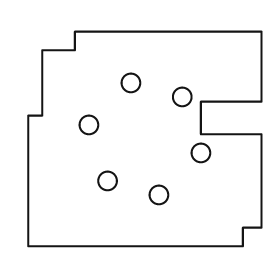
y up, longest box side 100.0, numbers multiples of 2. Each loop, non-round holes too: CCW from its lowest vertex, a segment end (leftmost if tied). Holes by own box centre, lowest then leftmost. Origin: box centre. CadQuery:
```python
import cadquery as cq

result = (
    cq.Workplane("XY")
    .moveTo(-50.0, -46.0)
    .lineTo(42.0, -46.0)
    .lineTo(42.0, -38.0)
    .lineTo(50.0, -38.0)
    .lineTo(50.0, 2.0)
    .lineTo(24.0, 2.0)
    .lineTo(24.0, 16.0)
    .lineTo(50.0, 16.0)
    .lineTo(50.0, 46.0)
    .lineTo(-30.0, 46.0)
    .lineTo(-30.0, 38.0)
    .lineTo(-44.0, 38.0)
    .lineTo(-44.0, 10.0)
    .lineTo(-50.0, 10.0)
    .close()
    .moveTo(6.0, -24.0)
    .circle(4.0)
    .moveTo(-16.0, -18.0)
    .circle(4.0)
    .moveTo(24.0, -6.0)
    .circle(4.0)
    .moveTo(-24.0, 6.0)
    .circle(4.0)
    .moveTo(16.0, 18.0)
    .circle(4.0)
    .moveTo(-6.0, 24.0)
    .circle(4.0)
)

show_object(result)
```